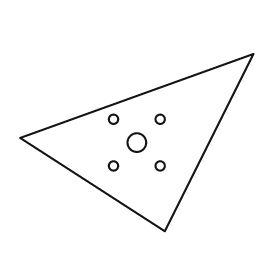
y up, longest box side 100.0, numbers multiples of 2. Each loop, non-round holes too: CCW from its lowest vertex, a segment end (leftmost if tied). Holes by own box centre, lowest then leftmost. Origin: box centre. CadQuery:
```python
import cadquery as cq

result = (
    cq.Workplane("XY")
    .moveTo(12.0, -38.0)
    .lineTo(50.0, 38.0)
    .lineTo(-50.0, 2.0)
    .close()
    .moveTo(-10.0, -10.0)
    .circle(2.0)
    .moveTo(10.0, -10.0)
    .circle(2.0)
    .moveTo(0.0, 0.0)
    .circle(4.0)
    .moveTo(-10.0, 10.0)
    .circle(2.0)
    .moveTo(10.0, 10.0)
    .circle(2.0)
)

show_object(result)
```